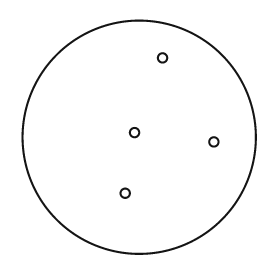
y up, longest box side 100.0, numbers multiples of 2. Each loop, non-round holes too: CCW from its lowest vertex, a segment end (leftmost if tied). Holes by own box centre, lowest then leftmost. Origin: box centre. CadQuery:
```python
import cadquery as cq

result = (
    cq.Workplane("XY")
    .moveTo(0.0, 0.0)
    .circle(50.0)
    .moveTo(-6.0, -24.0)
    .circle(2.0)
    .moveTo(32.0, -2.0)
    .circle(2.0)
    .moveTo(-2.0, 2.0)
    .circle(2.0)
    .moveTo(10.0, 34.0)
    .circle(2.0)
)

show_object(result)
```